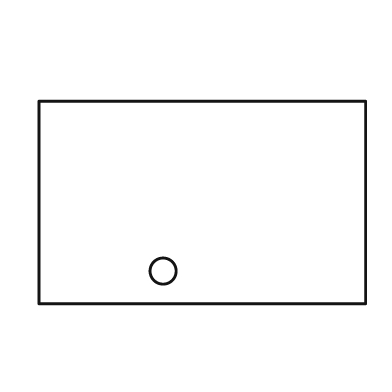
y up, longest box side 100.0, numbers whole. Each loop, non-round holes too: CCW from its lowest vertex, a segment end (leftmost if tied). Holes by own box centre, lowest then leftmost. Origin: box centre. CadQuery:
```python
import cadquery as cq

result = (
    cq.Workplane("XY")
    .moveTo(-50.0, -31.0)
    .lineTo(50.0, -31.0)
    .lineTo(50.0, 31.0)
    .lineTo(-50.0, 31.0)
    .close()
    .moveTo(-12.0, -21.0)
    .circle(4.0)
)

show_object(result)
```